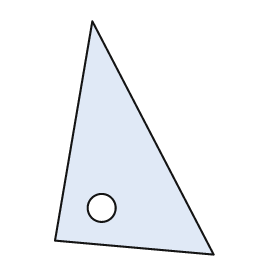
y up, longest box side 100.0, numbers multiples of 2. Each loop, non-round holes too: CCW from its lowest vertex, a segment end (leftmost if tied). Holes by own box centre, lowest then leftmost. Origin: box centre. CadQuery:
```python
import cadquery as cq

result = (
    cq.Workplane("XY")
    .moveTo(34.0, -50.0)
    .lineTo(-18.0, 50.0)
    .lineTo(-34.0, -44.0)
    .close()
    .moveTo(-14.0, -30.0)
    .circle(6.0)
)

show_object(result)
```